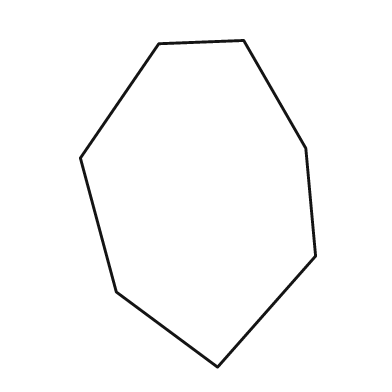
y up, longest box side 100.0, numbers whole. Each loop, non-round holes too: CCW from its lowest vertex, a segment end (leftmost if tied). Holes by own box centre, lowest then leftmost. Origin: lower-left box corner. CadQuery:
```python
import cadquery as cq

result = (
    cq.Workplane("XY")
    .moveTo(42.0, 0.0)
    .lineTo(72.0, 34.0)
    .lineTo(69.0, 67.0)
    .lineTo(50.0, 100.0)
    .lineTo(24.0, 99.0)
    .lineTo(0.0, 64.0)
    .lineTo(11.0, 23.0)
    .close()
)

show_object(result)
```